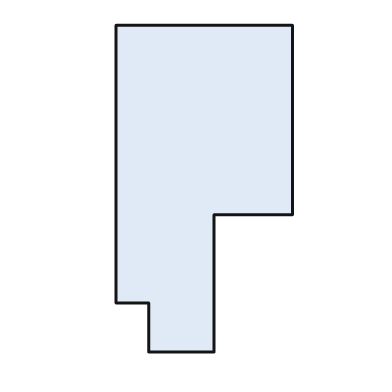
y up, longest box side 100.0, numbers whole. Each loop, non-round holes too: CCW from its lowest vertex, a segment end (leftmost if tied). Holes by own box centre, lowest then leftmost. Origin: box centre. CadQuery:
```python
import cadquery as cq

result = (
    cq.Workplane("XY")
    .moveTo(-17.0, -50.0)
    .lineTo(3.0, -50.0)
    .lineTo(3.0, -8.0)
    .lineTo(27.0, -8.0)
    .lineTo(27.0, 50.0)
    .lineTo(-27.0, 50.0)
    .lineTo(-27.0, -35.0)
    .lineTo(-17.0, -35.0)
    .close()
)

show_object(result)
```